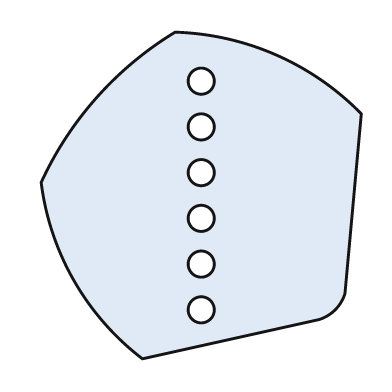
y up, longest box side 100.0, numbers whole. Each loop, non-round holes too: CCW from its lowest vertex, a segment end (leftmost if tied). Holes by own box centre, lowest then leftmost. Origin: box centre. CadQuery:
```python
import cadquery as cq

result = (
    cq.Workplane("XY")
    .moveTo(-18.0, -50.0)
    .lineTo(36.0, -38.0)
    .threePointArc((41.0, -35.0), (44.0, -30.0))
    .lineTo(49.0, 25.0)
    .threePointArc((23.0, 43.0), (-8.0, 50.0))
    .threePointArc((-32.0, 30.0), (-49.0, 4.0))
    .threePointArc((-39.0, -26.0), (-18.0, -50.0))
    .close()
    .moveTo(0.0, -35.0)
    .circle(4.0)
    .moveTo(0.0, -21.0)
    .circle(4.0)
    .moveTo(0.0, -7.0)
    .circle(4.0)
    .moveTo(0.0, 7.0)
    .circle(4.0)
    .moveTo(0.0, 21.0)
    .circle(4.0)
    .moveTo(0.0, 35.0)
    .circle(4.0)
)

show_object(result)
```